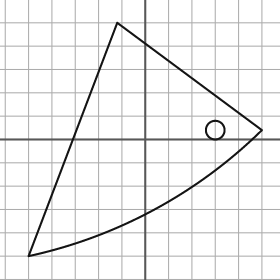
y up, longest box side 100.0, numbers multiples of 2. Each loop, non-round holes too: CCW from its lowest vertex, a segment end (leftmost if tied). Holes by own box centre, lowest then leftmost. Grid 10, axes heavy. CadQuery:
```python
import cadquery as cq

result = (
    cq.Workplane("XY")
    .moveTo(-50.0, -50.0)
    .threePointArc((4.0, -30.0), (50.0, 4.0))
    .lineTo(-12.0, 50.0)
    .close()
    .moveTo(30.0, 4.0)
    .circle(4.0)
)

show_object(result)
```